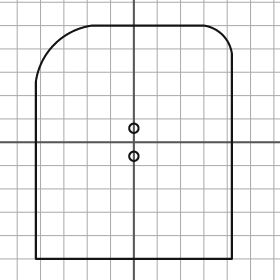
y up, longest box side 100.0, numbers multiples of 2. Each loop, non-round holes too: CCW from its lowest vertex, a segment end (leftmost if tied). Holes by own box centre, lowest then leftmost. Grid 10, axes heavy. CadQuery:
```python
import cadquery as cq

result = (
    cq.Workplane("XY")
    .moveTo(-42.0, -50.0)
    .lineTo(42.0, -50.0)
    .lineTo(42.0, 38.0)
    .threePointArc((38.0, 46.0), (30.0, 50.0))
    .lineTo(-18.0, 50.0)
    .threePointArc((-34.0, 42.0), (-42.0, 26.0))
    .close()
    .moveTo(0.0, -6.0)
    .circle(2.0)
    .moveTo(0.0, 6.0)
    .circle(2.0)
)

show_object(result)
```